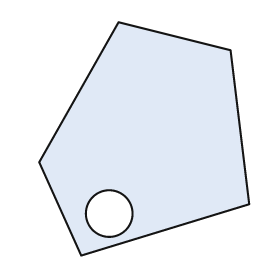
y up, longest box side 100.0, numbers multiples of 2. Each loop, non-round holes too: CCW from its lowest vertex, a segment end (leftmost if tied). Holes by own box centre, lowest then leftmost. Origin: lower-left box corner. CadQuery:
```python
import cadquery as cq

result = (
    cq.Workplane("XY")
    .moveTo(18.0, 0.0)
    .lineTo(90.0, 22.0)
    .lineTo(82.0, 88.0)
    .lineTo(34.0, 100.0)
    .lineTo(0.0, 40.0)
    .close()
    .moveTo(30.0, 18.0)
    .circle(10.0)
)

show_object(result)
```